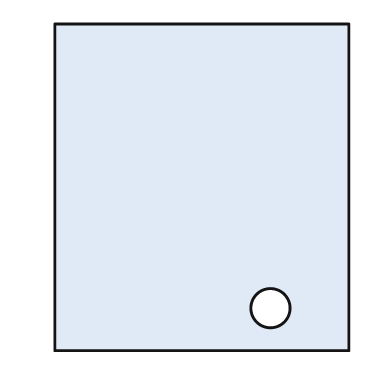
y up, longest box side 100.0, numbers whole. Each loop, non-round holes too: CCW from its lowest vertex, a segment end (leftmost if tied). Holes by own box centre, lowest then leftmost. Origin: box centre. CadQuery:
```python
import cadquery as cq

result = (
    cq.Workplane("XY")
    .moveTo(-45.0, -50.0)
    .lineTo(45.0, -50.0)
    .lineTo(45.0, 50.0)
    .lineTo(-45.0, 50.0)
    .close()
    .moveTo(21.0, -37.0)
    .circle(6.0)
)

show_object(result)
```